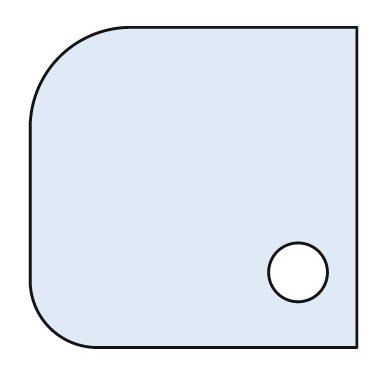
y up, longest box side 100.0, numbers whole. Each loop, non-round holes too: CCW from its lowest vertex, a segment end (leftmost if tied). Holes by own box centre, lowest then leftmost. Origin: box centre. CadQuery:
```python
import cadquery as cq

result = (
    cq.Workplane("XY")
    .moveTo(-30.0, -49.0)
    .lineTo(50.0, -49.0)
    .lineTo(50.0, 49.0)
    .lineTo(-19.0, 49.0)
    .threePointArc((-41.0, 40.0), (-50.0, 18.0))
    .lineTo(-50.0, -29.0)
    .threePointArc((-44.0, -43.0), (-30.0, -49.0))
    .close()
    .moveTo(32.0, -26.0)
    .circle(9.0)
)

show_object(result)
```